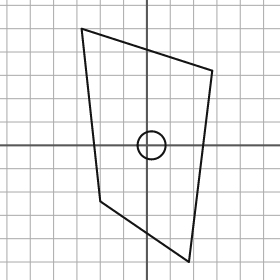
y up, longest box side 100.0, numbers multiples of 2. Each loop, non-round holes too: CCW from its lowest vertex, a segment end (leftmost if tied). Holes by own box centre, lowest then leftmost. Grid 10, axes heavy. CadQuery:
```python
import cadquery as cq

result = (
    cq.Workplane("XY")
    .moveTo(18.0, -50.0)
    .lineTo(28.0, 32.0)
    .lineTo(-28.0, 50.0)
    .lineTo(-20.0, -24.0)
    .close()
    .moveTo(2.0, 0.0)
    .circle(6.0)
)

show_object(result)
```